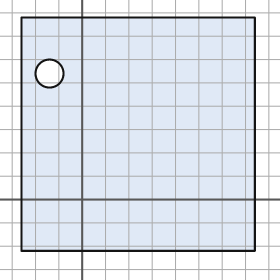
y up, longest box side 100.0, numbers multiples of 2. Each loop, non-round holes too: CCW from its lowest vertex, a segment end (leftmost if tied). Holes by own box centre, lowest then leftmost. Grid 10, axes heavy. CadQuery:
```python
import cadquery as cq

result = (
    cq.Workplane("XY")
    .moveTo(-26.0, -22.0)
    .lineTo(74.0, -22.0)
    .lineTo(74.0, 78.0)
    .lineTo(-26.0, 78.0)
    .close()
    .moveTo(-14.0, 54.0)
    .circle(6.0)
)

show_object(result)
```